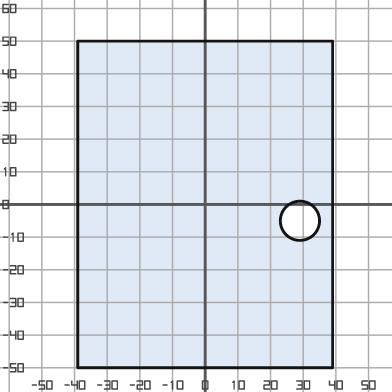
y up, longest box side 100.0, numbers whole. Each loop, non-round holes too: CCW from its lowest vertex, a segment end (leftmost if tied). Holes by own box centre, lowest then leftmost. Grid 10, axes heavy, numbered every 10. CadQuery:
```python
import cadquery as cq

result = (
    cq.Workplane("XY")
    .moveTo(-39.0, -50.0)
    .lineTo(39.0, -50.0)
    .lineTo(39.0, 50.0)
    .lineTo(-39.0, 50.0)
    .close()
    .moveTo(29.0, -5.0)
    .circle(6.0)
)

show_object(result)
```